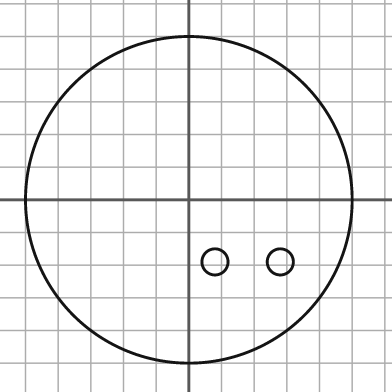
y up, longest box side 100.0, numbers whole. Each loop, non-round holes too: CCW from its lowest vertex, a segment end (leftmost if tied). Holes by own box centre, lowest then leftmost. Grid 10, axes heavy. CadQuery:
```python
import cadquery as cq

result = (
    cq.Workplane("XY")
    .moveTo(0.0, 0.0)
    .circle(50.0)
    .moveTo(8.0, -19.0)
    .circle(4.0)
    .moveTo(28.0, -19.0)
    .circle(4.0)
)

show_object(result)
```